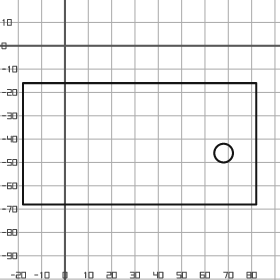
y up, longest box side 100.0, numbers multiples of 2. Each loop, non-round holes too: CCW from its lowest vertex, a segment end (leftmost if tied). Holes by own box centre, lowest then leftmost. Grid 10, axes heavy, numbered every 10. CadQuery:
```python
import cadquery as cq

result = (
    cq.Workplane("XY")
    .moveTo(-18.0, -68.0)
    .lineTo(82.0, -68.0)
    .lineTo(82.0, -16.0)
    .lineTo(-18.0, -16.0)
    .close()
    .moveTo(68.0, -46.0)
    .circle(4.0)
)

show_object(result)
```